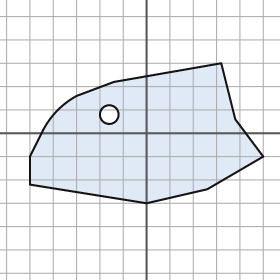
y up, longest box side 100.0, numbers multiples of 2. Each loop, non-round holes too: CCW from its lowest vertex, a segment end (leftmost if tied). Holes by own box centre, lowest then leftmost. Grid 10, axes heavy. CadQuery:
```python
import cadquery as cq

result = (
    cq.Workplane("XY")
    .moveTo(0.0, -30.0)
    .lineTo(26.0, -24.0)
    .lineTo(50.0, -10.0)
    .lineTo(38.0, 6.0)
    .lineTo(32.0, 30.0)
    .lineTo(-14.0, 22.0)
    .lineTo(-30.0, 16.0)
    .threePointArc((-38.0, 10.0), (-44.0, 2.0))
    .lineTo(-50.0, -10.0)
    .lineTo(-50.0, -22.0)
    .close()
    .moveTo(-16.0, 8.0)
    .circle(4.0)
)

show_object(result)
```